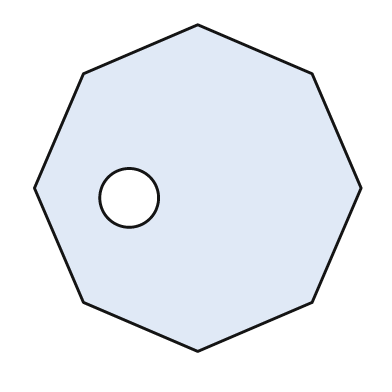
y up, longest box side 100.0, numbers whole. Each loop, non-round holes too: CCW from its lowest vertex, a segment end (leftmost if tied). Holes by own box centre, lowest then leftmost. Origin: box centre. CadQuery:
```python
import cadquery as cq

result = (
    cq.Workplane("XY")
    .moveTo(0.0, -50.0)
    .lineTo(35.0, -35.0)
    .lineTo(50.0, 0.0)
    .lineTo(35.0, 35.0)
    .lineTo(0.0, 50.0)
    .lineTo(-35.0, 35.0)
    .lineTo(-50.0, 0.0)
    .lineTo(-35.0, -35.0)
    .close()
    .moveTo(-21.0, -3.0)
    .circle(9.0)
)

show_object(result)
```